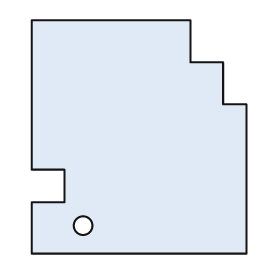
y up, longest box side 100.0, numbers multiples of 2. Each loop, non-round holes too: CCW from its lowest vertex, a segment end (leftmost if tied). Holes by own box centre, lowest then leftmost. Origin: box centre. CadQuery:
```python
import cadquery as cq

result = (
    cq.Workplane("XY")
    .moveTo(-46.0, -50.0)
    .lineTo(46.0, -50.0)
    .lineTo(46.0, 14.0)
    .lineTo(36.0, 14.0)
    .lineTo(36.0, 32.0)
    .lineTo(22.0, 32.0)
    .lineTo(22.0, 50.0)
    .lineTo(-46.0, 50.0)
    .lineTo(-46.0, -14.0)
    .lineTo(-32.0, -14.0)
    .lineTo(-32.0, -28.0)
    .lineTo(-46.0, -28.0)
    .close()
    .moveTo(-24.0, -38.0)
    .circle(4.0)
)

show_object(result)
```